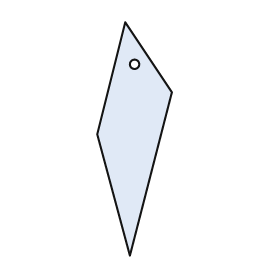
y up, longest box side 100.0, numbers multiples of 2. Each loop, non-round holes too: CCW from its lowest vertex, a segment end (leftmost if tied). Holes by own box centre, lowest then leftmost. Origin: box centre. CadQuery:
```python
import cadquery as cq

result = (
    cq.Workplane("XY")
    .moveTo(-2.0, -50.0)
    .lineTo(16.0, 20.0)
    .lineTo(-4.0, 50.0)
    .lineTo(-16.0, 2.0)
    .close()
    .moveTo(0.0, 32.0)
    .circle(2.0)
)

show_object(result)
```